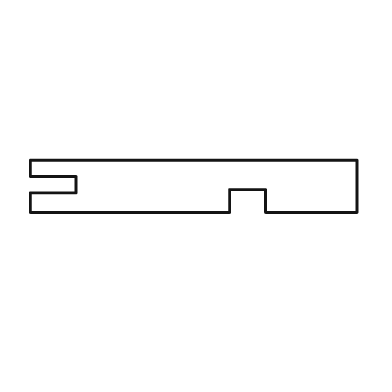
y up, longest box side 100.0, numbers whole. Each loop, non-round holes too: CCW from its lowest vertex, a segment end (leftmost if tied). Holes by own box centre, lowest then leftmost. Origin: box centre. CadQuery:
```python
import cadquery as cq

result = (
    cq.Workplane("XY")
    .moveTo(-50.0, -8.0)
    .lineTo(11.0, -8.0)
    .lineTo(11.0, -1.0)
    .lineTo(22.0, -1.0)
    .lineTo(22.0, -8.0)
    .lineTo(50.0, -8.0)
    .lineTo(50.0, 8.0)
    .lineTo(-50.0, 8.0)
    .lineTo(-50.0, 3.0)
    .lineTo(-36.0, 3.0)
    .lineTo(-36.0, -2.0)
    .lineTo(-50.0, -2.0)
    .close()
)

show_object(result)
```